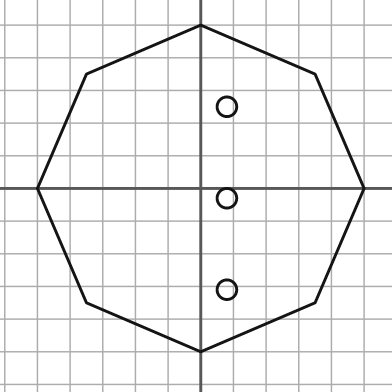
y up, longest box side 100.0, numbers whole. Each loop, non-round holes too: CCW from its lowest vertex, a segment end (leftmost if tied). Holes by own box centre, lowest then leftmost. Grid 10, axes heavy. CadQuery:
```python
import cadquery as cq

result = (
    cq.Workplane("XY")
    .moveTo(0.0, -50.0)
    .lineTo(35.0, -35.0)
    .lineTo(50.0, 0.0)
    .lineTo(35.0, 35.0)
    .lineTo(0.0, 50.0)
    .lineTo(-35.0, 35.0)
    .lineTo(-50.0, 0.0)
    .lineTo(-35.0, -35.0)
    .close()
    .moveTo(8.0, -31.0)
    .circle(3.0)
    .moveTo(8.0, -3.0)
    .circle(3.0)
    .moveTo(8.0, 25.0)
    .circle(3.0)
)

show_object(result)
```